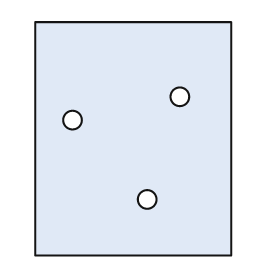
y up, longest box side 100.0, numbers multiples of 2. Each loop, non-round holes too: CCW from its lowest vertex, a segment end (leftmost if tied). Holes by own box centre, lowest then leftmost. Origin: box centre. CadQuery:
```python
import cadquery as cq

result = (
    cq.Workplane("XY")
    .moveTo(-42.0, -50.0)
    .lineTo(42.0, -50.0)
    .lineTo(42.0, 50.0)
    .lineTo(-42.0, 50.0)
    .close()
    .moveTo(6.0, -26.0)
    .circle(4.0)
    .moveTo(-26.0, 8.0)
    .circle(4.0)
    .moveTo(20.0, 18.0)
    .circle(4.0)
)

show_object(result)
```